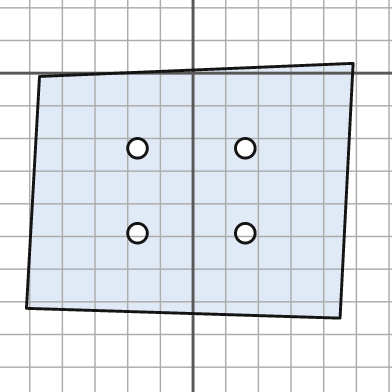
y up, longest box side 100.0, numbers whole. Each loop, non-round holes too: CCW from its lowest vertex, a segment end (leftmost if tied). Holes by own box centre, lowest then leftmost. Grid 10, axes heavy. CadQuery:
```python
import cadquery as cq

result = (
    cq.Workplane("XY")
    .moveTo(45.0, -75.0)
    .lineTo(49.0, 3.0)
    .lineTo(-47.0, -1.0)
    .lineTo(-51.0, -72.0)
    .close()
    .moveTo(-17.0, -49.0)
    .circle(3.0)
    .moveTo(16.0, -49.0)
    .circle(3.0)
    .moveTo(-17.0, -23.0)
    .circle(3.0)
    .moveTo(16.0, -23.0)
    .circle(3.0)
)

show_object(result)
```